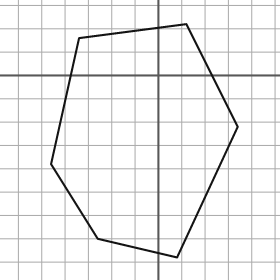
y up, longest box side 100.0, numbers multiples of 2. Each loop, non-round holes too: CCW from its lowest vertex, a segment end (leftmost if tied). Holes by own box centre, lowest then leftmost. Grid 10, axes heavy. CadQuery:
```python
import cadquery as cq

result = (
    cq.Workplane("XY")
    .moveTo(8.0, -78.0)
    .lineTo(34.0, -22.0)
    .lineTo(12.0, 22.0)
    .lineTo(-34.0, 16.0)
    .lineTo(-46.0, -38.0)
    .lineTo(-26.0, -70.0)
    .close()
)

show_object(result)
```